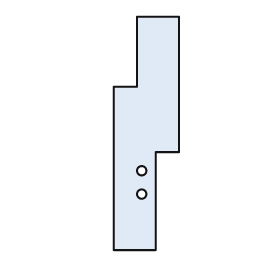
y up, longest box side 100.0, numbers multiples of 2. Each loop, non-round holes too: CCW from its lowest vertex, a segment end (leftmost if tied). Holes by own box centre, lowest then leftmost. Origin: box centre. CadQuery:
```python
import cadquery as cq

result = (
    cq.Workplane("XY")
    .moveTo(-14.0, -50.0)
    .lineTo(4.0, -50.0)
    .lineTo(4.0, -8.0)
    .lineTo(14.0, -8.0)
    .lineTo(14.0, 50.0)
    .lineTo(-4.0, 50.0)
    .lineTo(-4.0, 20.0)
    .lineTo(-14.0, 20.0)
    .close()
    .moveTo(-2.0, -26.0)
    .circle(2.0)
    .moveTo(-2.0, -16.0)
    .circle(2.0)
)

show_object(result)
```